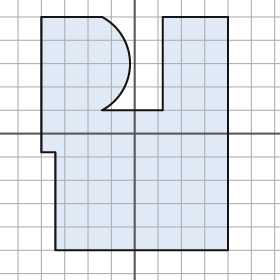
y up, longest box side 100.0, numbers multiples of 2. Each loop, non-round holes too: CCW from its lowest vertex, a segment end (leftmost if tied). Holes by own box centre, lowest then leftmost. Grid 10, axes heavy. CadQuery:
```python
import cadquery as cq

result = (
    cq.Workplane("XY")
    .moveTo(-34.0, -50.0)
    .lineTo(40.0, -50.0)
    .lineTo(40.0, 50.0)
    .lineTo(12.0, 50.0)
    .lineTo(12.0, 10.0)
    .lineTo(-14.0, 10.0)
    .threePointArc((-2.0, 30.0), (-14.0, 50.0))
    .lineTo(-40.0, 50.0)
    .lineTo(-40.0, -8.0)
    .lineTo(-34.0, -8.0)
    .close()
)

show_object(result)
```